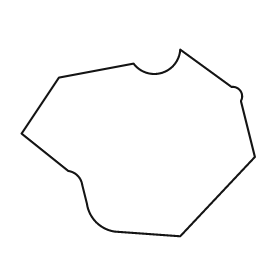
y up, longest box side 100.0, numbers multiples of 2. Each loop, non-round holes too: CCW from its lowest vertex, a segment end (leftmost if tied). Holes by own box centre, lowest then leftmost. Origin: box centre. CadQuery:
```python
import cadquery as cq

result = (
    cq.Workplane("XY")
    .moveTo(18.0, -40.0)
    .lineTo(50.0, -6.0)
    .lineTo(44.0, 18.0)
    .threePointArc((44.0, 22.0), (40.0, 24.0))
    .lineTo(18.0, 40.0)
    .threePointArc((10.0, 30.0), (-2.0, 34.0))
    .lineTo(-34.0, 28.0)
    .lineTo(-50.0, 4.0)
    .lineTo(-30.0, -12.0)
    .threePointArc((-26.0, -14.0), (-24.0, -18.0))
    .lineTo(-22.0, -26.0)
    .threePointArc((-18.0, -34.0), (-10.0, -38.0))
    .close()
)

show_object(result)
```